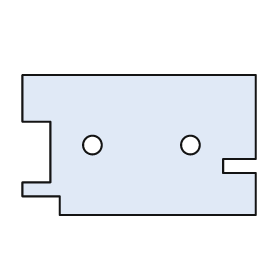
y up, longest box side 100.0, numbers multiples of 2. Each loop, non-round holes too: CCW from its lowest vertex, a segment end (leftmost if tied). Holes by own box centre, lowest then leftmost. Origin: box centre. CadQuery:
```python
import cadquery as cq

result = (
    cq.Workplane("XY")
    .moveTo(-34.0, -30.0)
    .lineTo(50.0, -30.0)
    .lineTo(50.0, -12.0)
    .lineTo(36.0, -12.0)
    .lineTo(36.0, -6.0)
    .lineTo(50.0, -6.0)
    .lineTo(50.0, 30.0)
    .lineTo(-50.0, 30.0)
    .lineTo(-50.0, 10.0)
    .lineTo(-38.0, 10.0)
    .lineTo(-38.0, -16.0)
    .lineTo(-50.0, -16.0)
    .lineTo(-50.0, -22.0)
    .lineTo(-34.0, -22.0)
    .close()
    .moveTo(-20.0, 0.0)
    .circle(4.0)
    .moveTo(22.0, 0.0)
    .circle(4.0)
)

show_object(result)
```